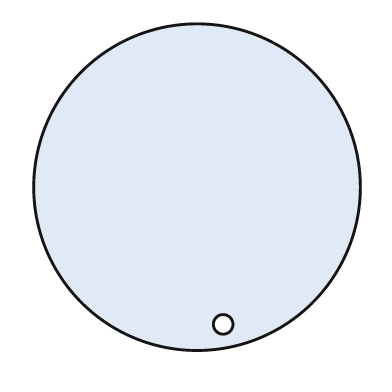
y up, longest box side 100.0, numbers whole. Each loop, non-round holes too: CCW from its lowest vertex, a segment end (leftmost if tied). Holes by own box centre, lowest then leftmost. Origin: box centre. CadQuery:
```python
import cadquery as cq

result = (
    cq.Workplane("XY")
    .moveTo(0.0, 0.0)
    .circle(50.0)
    .moveTo(8.0, -42.0)
    .circle(3.0)
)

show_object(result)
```